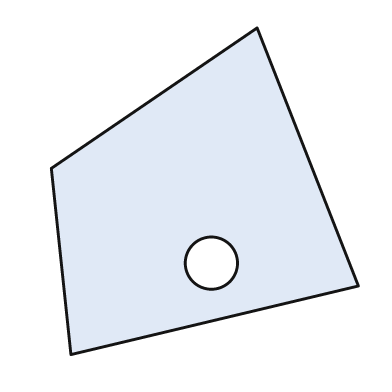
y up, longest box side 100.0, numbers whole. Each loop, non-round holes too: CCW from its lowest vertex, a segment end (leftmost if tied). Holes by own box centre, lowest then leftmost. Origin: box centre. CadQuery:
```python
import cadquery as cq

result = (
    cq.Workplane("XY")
    .moveTo(-41.0, -50.0)
    .lineTo(47.0, -29.0)
    .lineTo(16.0, 50.0)
    .lineTo(-47.0, 7.0)
    .close()
    .moveTo(2.0, -22.0)
    .circle(8.0)
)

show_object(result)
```